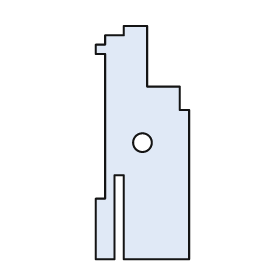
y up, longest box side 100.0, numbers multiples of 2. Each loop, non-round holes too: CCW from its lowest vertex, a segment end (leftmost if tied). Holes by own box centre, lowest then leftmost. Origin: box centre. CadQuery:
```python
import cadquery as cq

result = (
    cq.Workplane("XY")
    .moveTo(-20.0, -50.0)
    .lineTo(-12.0, -50.0)
    .lineTo(-12.0, -14.0)
    .lineTo(-8.0, -14.0)
    .lineTo(-8.0, -50.0)
    .lineTo(20.0, -50.0)
    .lineTo(20.0, 14.0)
    .lineTo(16.0, 14.0)
    .lineTo(16.0, 24.0)
    .lineTo(2.0, 24.0)
    .lineTo(2.0, 50.0)
    .lineTo(-8.0, 50.0)
    .lineTo(-8.0, 46.0)
    .lineTo(-16.0, 46.0)
    .lineTo(-16.0, 42.0)
    .lineTo(-20.0, 42.0)
    .lineTo(-20.0, 38.0)
    .lineTo(-16.0, 38.0)
    .lineTo(-16.0, -24.0)
    .lineTo(-20.0, -24.0)
    .close()
    .moveTo(0.0, 0.0)
    .circle(4.0)
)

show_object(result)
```